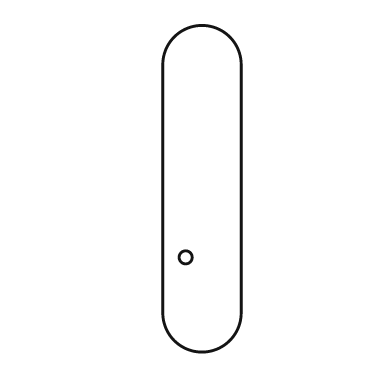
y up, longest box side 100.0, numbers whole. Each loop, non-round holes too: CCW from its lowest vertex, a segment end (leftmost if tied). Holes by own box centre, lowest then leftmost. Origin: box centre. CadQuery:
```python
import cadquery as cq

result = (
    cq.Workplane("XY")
    .moveTo(-12.0, -38.0)
    .threePointArc((0.0, -50.0), (12.0, -38.0))
    .lineTo(12.0, 38.0)
    .threePointArc((0.0, 50.0), (-12.0, 38.0))
    .close()
    .moveTo(-5.0, -21.0)
    .circle(2.0)
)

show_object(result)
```